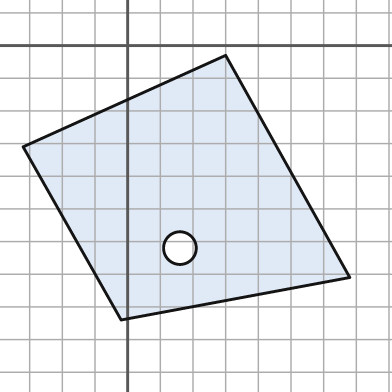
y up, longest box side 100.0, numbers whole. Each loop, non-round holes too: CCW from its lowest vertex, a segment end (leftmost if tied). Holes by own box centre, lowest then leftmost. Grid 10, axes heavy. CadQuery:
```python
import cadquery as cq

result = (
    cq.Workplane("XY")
    .moveTo(-2.0, -84.0)
    .lineTo(68.0, -71.0)
    .lineTo(30.0, -3.0)
    .lineTo(-32.0, -31.0)
    .close()
    .moveTo(16.0, -62.0)
    .circle(5.0)
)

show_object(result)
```